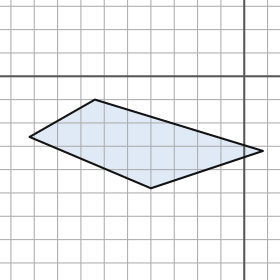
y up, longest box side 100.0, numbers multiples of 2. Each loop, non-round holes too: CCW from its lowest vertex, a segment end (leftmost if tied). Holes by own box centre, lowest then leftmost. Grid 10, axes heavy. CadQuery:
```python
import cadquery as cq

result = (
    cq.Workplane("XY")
    .moveTo(-40.0, -48.0)
    .lineTo(8.0, -32.0)
    .lineTo(-64.0, -10.0)
    .lineTo(-92.0, -26.0)
    .close()
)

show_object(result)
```